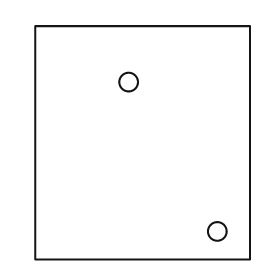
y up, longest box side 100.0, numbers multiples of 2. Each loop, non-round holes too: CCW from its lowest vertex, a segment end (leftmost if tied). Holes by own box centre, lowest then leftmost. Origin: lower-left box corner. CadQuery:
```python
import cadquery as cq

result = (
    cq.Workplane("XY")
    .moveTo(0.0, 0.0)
    .lineTo(92.0, 0.0)
    .lineTo(92.0, 100.0)
    .lineTo(0.0, 100.0)
    .close()
    .moveTo(78.0, 12.0)
    .circle(4.0)
    .moveTo(40.0, 76.0)
    .circle(4.0)
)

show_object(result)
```